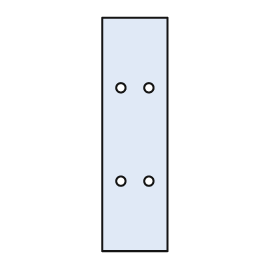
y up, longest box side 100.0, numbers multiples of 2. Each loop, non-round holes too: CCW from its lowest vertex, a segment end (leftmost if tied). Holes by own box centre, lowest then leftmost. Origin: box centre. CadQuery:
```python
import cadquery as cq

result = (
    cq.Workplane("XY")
    .moveTo(-14.0, -50.0)
    .lineTo(14.0, -50.0)
    .lineTo(14.0, 50.0)
    .lineTo(-14.0, 50.0)
    .close()
    .moveTo(-6.0, -20.0)
    .circle(2.0)
    .moveTo(6.0, -20.0)
    .circle(2.0)
    .moveTo(-6.0, 20.0)
    .circle(2.0)
    .moveTo(6.0, 20.0)
    .circle(2.0)
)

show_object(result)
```